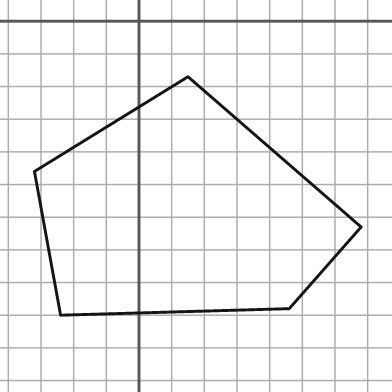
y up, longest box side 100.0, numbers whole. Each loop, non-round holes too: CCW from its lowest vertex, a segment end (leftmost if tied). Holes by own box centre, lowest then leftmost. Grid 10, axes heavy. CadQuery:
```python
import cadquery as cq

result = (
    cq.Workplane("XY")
    .moveTo(-24.0, -90.0)
    .lineTo(46.0, -88.0)
    .lineTo(68.0, -63.0)
    .lineTo(15.0, -17.0)
    .lineTo(-32.0, -46.0)
    .close()
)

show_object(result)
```